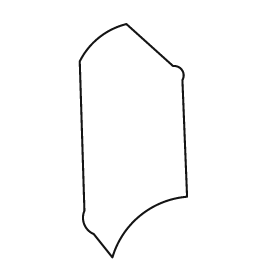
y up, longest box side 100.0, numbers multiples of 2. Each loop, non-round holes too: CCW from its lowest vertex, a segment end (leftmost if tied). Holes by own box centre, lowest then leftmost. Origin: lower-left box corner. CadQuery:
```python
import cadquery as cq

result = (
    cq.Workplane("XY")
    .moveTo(14.0, 0.0)
    .threePointArc((26.0, 18.0), (46.0, 26.0))
    .lineTo(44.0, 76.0)
    .threePointArc((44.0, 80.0), (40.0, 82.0))
    .lineTo(20.0, 100.0)
    .threePointArc((8.0, 94.0), (0.0, 84.0))
    .lineTo(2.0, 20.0)
    .threePointArc((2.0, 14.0), (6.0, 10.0))
    .close()
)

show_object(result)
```